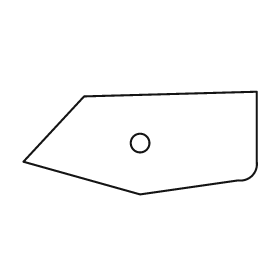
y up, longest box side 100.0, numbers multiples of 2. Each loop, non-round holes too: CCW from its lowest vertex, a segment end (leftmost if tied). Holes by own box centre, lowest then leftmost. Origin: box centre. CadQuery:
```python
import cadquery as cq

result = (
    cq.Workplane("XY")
    .moveTo(0.0, -22.0)
    .lineTo(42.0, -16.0)
    .threePointArc((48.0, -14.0), (50.0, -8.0))
    .lineTo(50.0, 22.0)
    .lineTo(-24.0, 20.0)
    .lineTo(-50.0, -8.0)
    .close()
    .moveTo(0.0, 0.0)
    .circle(4.0)
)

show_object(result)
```